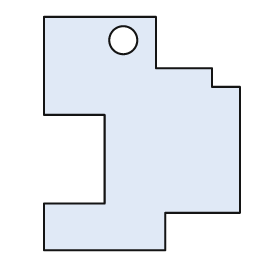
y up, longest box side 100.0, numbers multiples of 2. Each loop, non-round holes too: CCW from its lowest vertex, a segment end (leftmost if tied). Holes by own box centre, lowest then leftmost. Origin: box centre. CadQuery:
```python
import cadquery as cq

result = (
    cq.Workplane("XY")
    .moveTo(-42.0, -50.0)
    .lineTo(10.0, -50.0)
    .lineTo(10.0, -34.0)
    .lineTo(42.0, -34.0)
    .lineTo(42.0, 20.0)
    .lineTo(30.0, 20.0)
    .lineTo(30.0, 28.0)
    .lineTo(6.0, 28.0)
    .lineTo(6.0, 50.0)
    .lineTo(-42.0, 50.0)
    .lineTo(-42.0, 8.0)
    .lineTo(-16.0, 8.0)
    .lineTo(-16.0, -30.0)
    .lineTo(-42.0, -30.0)
    .close()
    .moveTo(-8.0, 40.0)
    .circle(6.0)
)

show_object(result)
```